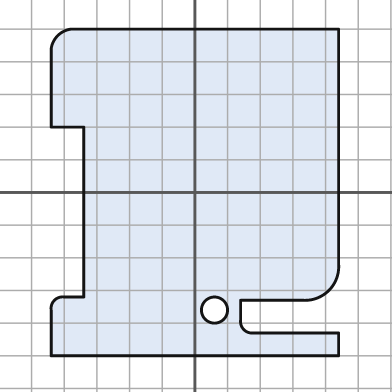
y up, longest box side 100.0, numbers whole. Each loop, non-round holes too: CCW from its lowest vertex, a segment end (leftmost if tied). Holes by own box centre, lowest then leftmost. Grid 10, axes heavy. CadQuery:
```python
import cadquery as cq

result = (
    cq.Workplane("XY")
    .moveTo(-44.0, -50.0)
    .lineTo(44.0, -50.0)
    .lineTo(44.0, -43.0)
    .lineTo(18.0, -43.0)
    .threePointArc((15.0, -42.0), (14.0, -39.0))
    .lineTo(14.0, -33.0)
    .lineTo(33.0, -33.0)
    .threePointArc((41.0, -30.0), (44.0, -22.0))
    .lineTo(44.0, 50.0)
    .lineTo(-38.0, 50.0)
    .threePointArc((-42.0, 48.0), (-44.0, 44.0))
    .lineTo(-44.0, 20.0)
    .lineTo(-34.0, 20.0)
    .lineTo(-34.0, -32.0)
    .lineTo(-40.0, -32.0)
    .threePointArc((-43.0, -33.0), (-44.0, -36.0))
    .close()
    .moveTo(6.0, -36.0)
    .circle(4.0)
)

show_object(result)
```